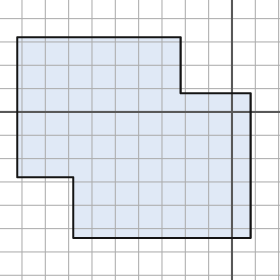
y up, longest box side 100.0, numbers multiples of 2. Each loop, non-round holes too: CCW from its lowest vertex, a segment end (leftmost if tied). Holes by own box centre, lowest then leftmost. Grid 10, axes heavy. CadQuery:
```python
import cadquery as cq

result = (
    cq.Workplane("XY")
    .moveTo(-68.0, -54.0)
    .lineTo(8.0, -54.0)
    .lineTo(8.0, 8.0)
    .lineTo(-22.0, 8.0)
    .lineTo(-22.0, 32.0)
    .lineTo(-92.0, 32.0)
    .lineTo(-92.0, -28.0)
    .lineTo(-68.0, -28.0)
    .close()
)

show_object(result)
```